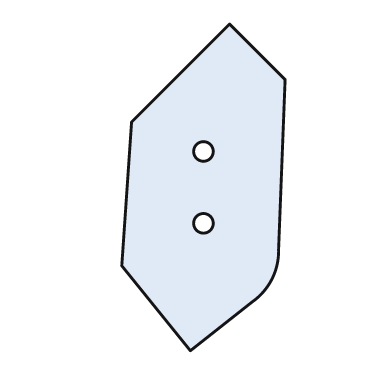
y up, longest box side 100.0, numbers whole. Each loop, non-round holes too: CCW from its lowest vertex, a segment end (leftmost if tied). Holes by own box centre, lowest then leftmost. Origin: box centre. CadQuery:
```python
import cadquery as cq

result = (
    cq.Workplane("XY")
    .moveTo(-4.0, -50.0)
    .lineTo(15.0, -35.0)
    .threePointArc((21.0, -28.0), (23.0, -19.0))
    .lineTo(25.0, 33.0)
    .lineTo(8.0, 50.0)
    .lineTo(-22.0, 20.0)
    .lineTo(-25.0, -24.0)
    .close()
    .moveTo(0.0, -11.0)
    .circle(3.0)
    .moveTo(0.0, 11.0)
    .circle(3.0)
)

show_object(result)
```